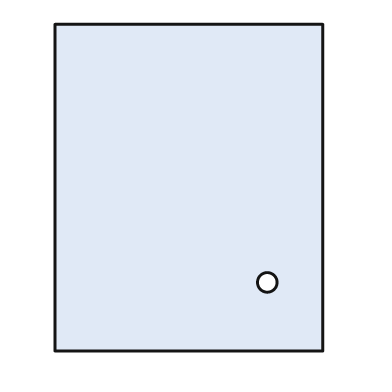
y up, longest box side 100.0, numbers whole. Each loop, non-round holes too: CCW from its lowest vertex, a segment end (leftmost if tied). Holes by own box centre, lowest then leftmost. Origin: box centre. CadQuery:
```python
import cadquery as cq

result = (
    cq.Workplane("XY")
    .moveTo(-41.0, -50.0)
    .lineTo(41.0, -50.0)
    .lineTo(41.0, 50.0)
    .lineTo(-41.0, 50.0)
    .close()
    .moveTo(24.0, -29.0)
    .circle(3.0)
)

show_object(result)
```